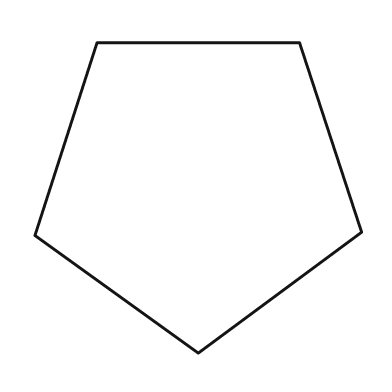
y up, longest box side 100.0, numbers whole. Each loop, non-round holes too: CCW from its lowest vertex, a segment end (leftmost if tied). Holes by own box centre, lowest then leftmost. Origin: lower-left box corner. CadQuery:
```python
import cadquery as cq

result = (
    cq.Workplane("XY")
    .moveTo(50.0, 0.0)
    .lineTo(100.0, 37.0)
    .lineTo(81.0, 95.0)
    .lineTo(19.0, 95.0)
    .lineTo(0.0, 36.0)
    .close()
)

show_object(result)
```